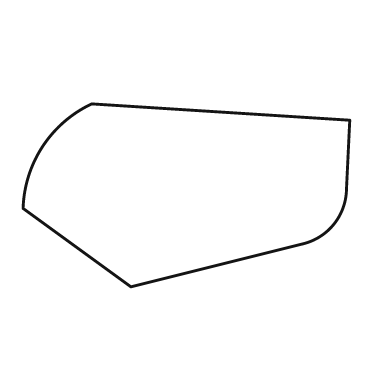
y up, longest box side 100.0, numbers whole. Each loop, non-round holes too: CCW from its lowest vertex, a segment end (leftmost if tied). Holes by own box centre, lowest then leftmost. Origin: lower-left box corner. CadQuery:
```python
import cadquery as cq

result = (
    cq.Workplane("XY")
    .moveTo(33.0, 0.0)
    .lineTo(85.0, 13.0)
    .threePointArc((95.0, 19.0), (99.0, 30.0))
    .lineTo(100.0, 51.0)
    .lineTo(21.0, 56.0)
    .threePointArc((6.0, 43.0), (0.0, 24.0))
    .close()
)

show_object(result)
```